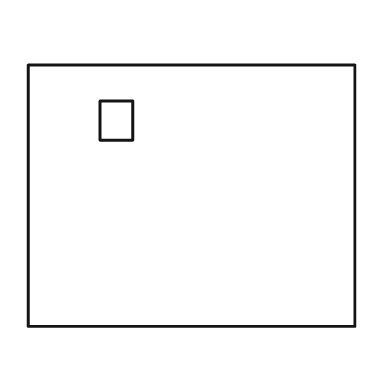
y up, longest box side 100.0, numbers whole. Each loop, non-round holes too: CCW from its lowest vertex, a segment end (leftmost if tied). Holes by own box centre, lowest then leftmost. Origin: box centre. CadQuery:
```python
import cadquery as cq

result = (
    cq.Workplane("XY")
    .moveTo(-50.0, -40.0)
    .lineTo(50.0, -40.0)
    .lineTo(50.0, 40.0)
    .lineTo(-50.0, 40.0)
    .close()
    .moveTo(-28.0, 17.0)
    .lineTo(-18.0, 17.0)
    .lineTo(-18.0, 29.0)
    .lineTo(-28.0, 29.0)
    .close()
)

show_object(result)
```